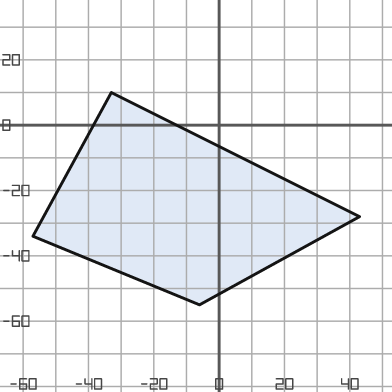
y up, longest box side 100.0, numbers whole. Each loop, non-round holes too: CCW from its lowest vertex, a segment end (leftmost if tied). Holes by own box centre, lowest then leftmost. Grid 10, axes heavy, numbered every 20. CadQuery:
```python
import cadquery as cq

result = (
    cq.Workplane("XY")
    .moveTo(-6.0, -55.0)
    .lineTo(43.0, -28.0)
    .lineTo(-33.0, 10.0)
    .lineTo(-57.0, -34.0)
    .close()
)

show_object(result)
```